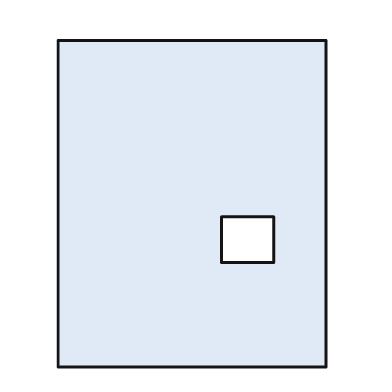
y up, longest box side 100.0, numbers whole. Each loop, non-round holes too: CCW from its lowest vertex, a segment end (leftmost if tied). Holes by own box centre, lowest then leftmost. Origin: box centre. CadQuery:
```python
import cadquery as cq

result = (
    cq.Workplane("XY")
    .moveTo(-41.0, -50.0)
    .lineTo(41.0, -50.0)
    .lineTo(41.0, 50.0)
    .lineTo(-41.0, 50.0)
    .close()
    .moveTo(9.0, -18.0)
    .lineTo(25.0, -18.0)
    .lineTo(25.0, -4.0)
    .lineTo(9.0, -4.0)
    .close()
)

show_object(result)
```